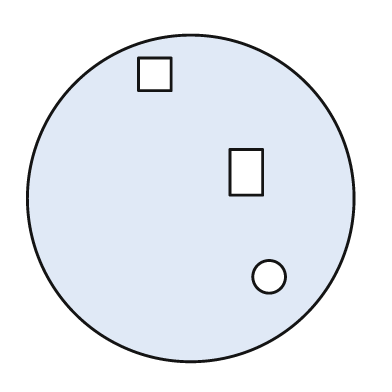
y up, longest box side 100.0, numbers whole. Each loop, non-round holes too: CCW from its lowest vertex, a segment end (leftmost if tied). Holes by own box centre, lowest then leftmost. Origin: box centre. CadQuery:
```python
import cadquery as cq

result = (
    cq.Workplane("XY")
    .moveTo(0.0, 0.0)
    .circle(50.0)
    .moveTo(24.0, -24.0)
    .circle(5.0)
    .moveTo(12.0, 1.0)
    .lineTo(22.0, 1.0)
    .lineTo(22.0, 15.0)
    .lineTo(12.0, 15.0)
    .close()
    .moveTo(-16.0, 33.0)
    .lineTo(-6.0, 33.0)
    .lineTo(-6.0, 43.0)
    .lineTo(-16.0, 43.0)
    .close()
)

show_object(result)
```